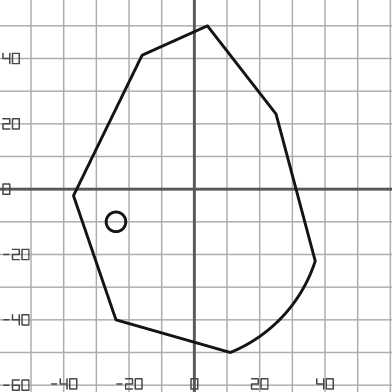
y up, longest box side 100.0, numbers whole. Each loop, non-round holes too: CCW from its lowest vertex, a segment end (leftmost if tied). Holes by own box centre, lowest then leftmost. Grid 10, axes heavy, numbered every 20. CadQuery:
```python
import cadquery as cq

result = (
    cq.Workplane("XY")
    .moveTo(11.0, -50.0)
    .threePointArc((27.0, -39.0), (37.0, -22.0))
    .lineTo(25.0, 23.0)
    .lineTo(4.0, 50.0)
    .lineTo(-16.0, 41.0)
    .lineTo(-37.0, -2.0)
    .lineTo(-24.0, -40.0)
    .close()
    .moveTo(-24.0, -10.0)
    .circle(3.0)
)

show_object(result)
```